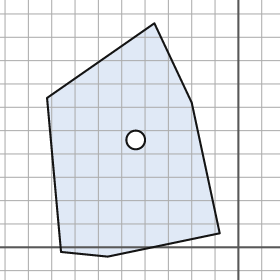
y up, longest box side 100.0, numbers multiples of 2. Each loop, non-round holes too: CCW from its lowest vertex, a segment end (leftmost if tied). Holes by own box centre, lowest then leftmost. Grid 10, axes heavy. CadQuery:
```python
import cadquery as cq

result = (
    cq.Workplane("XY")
    .moveTo(-56.0, -4.0)
    .lineTo(-8.0, 6.0)
    .lineTo(-20.0, 62.0)
    .lineTo(-36.0, 96.0)
    .lineTo(-82.0, 64.0)
    .lineTo(-76.0, -2.0)
    .close()
    .moveTo(-44.0, 46.0)
    .circle(4.0)
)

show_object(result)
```